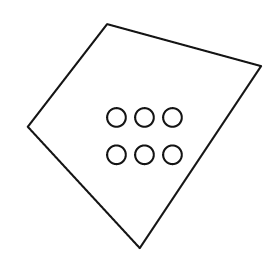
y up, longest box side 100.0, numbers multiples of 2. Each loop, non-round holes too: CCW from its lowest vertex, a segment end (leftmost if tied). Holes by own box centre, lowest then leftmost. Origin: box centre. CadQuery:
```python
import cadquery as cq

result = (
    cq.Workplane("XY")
    .moveTo(-2.0, -48.0)
    .lineTo(50.0, 30.0)
    .lineTo(-16.0, 48.0)
    .lineTo(-50.0, 4.0)
    .close()
    .moveTo(-12.0, -8.0)
    .circle(4.0)
    .moveTo(0.0, -8.0)
    .circle(4.0)
    .moveTo(12.0, -8.0)
    .circle(4.0)
    .moveTo(-12.0, 8.0)
    .circle(4.0)
    .moveTo(0.0, 8.0)
    .circle(4.0)
    .moveTo(12.0, 8.0)
    .circle(4.0)
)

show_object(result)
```